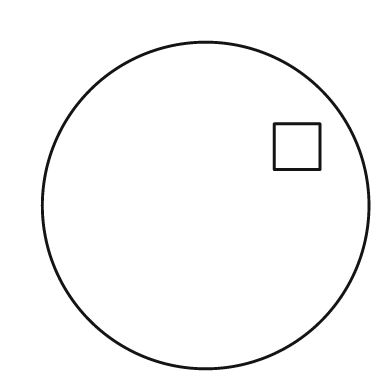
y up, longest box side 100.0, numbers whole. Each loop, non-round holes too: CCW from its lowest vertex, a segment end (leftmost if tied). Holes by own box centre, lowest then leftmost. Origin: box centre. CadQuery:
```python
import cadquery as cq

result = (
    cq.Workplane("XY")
    .moveTo(0.0, 0.0)
    .circle(50.0)
    .moveTo(21.0, 11.0)
    .lineTo(35.0, 11.0)
    .lineTo(35.0, 25.0)
    .lineTo(21.0, 25.0)
    .close()
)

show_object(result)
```